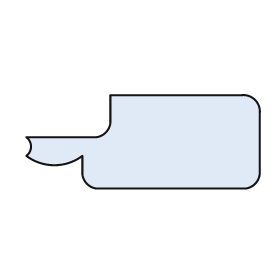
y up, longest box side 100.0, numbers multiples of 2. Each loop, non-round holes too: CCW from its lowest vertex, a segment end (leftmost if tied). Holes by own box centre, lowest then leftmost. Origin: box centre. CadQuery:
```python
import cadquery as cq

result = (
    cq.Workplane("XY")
    .moveTo(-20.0, -20.0)
    .lineTo(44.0, -20.0)
    .threePointArc((48.0, -18.0), (50.0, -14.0))
    .lineTo(50.0, 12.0)
    .threePointArc((48.0, 18.0), (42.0, 20.0))
    .lineTo(-14.0, 20.0)
    .lineTo(-14.0, 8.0)
    .threePointArc((-16.0, 4.0), (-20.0, 2.0))
    .lineTo(-50.0, 2.0)
    .threePointArc((-48.0, -2.0), (-50.0, -6.0))
    .threePointArc((-38.0, -10.0), (-26.0, -6.0))
    .lineTo(-26.0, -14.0)
    .threePointArc((-24.0, -18.0), (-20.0, -20.0))
    .close()
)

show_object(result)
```